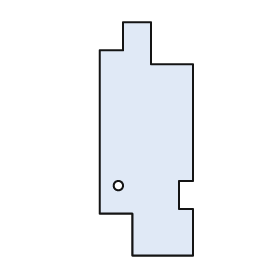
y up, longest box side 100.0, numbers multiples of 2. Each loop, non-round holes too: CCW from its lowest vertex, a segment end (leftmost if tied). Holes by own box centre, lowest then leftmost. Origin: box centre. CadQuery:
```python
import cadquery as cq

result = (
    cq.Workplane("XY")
    .moveTo(-6.0, -50.0)
    .lineTo(20.0, -50.0)
    .lineTo(20.0, -30.0)
    .lineTo(14.0, -30.0)
    .lineTo(14.0, -18.0)
    .lineTo(20.0, -18.0)
    .lineTo(20.0, 32.0)
    .lineTo(2.0, 32.0)
    .lineTo(2.0, 50.0)
    .lineTo(-10.0, 50.0)
    .lineTo(-10.0, 38.0)
    .lineTo(-20.0, 38.0)
    .lineTo(-20.0, -32.0)
    .lineTo(-6.0, -32.0)
    .close()
    .moveTo(-12.0, -20.0)
    .circle(2.0)
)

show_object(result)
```